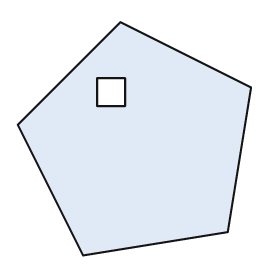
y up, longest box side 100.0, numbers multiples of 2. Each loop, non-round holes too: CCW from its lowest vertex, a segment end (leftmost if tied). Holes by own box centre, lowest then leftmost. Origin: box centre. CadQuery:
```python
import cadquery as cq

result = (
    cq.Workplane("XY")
    .moveTo(-22.0, -50.0)
    .lineTo(40.0, -40.0)
    .lineTo(50.0, 22.0)
    .lineTo(-6.0, 50.0)
    .lineTo(-50.0, 6.0)
    .close()
    .moveTo(-16.0, 14.0)
    .lineTo(-4.0, 14.0)
    .lineTo(-4.0, 26.0)
    .lineTo(-16.0, 26.0)
    .close()
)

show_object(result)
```